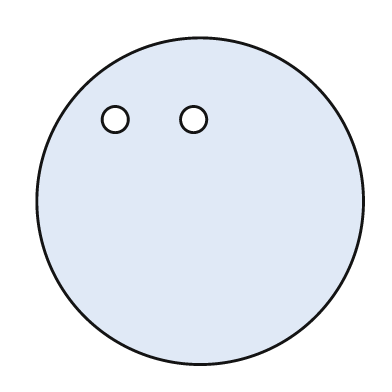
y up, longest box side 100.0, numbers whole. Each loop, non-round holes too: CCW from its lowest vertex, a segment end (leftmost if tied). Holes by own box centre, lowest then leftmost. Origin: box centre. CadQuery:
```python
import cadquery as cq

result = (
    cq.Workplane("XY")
    .moveTo(0.0, 0.0)
    .circle(50.0)
    .moveTo(-26.0, 25.0)
    .circle(4.0)
    .moveTo(-2.0, 25.0)
    .circle(4.0)
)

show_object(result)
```